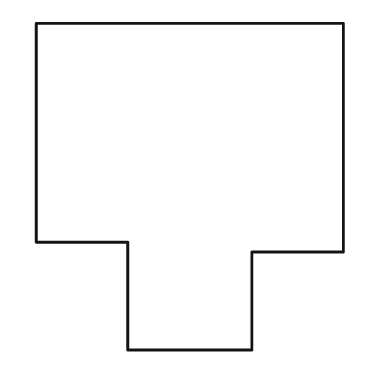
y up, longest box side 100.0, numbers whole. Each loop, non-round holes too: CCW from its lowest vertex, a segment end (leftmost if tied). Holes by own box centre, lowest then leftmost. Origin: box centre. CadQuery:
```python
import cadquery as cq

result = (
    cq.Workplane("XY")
    .moveTo(-19.0, -50.0)
    .lineTo(19.0, -50.0)
    .lineTo(19.0, -20.0)
    .lineTo(47.0, -20.0)
    .lineTo(47.0, 50.0)
    .lineTo(-47.0, 50.0)
    .lineTo(-47.0, -17.0)
    .lineTo(-19.0, -17.0)
    .close()
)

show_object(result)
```